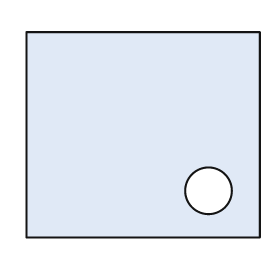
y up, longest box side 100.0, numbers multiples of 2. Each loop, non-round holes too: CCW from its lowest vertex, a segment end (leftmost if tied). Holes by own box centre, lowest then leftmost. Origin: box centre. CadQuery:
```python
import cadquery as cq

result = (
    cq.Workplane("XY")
    .moveTo(-50.0, -44.0)
    .lineTo(50.0, -44.0)
    .lineTo(50.0, 44.0)
    .lineTo(-50.0, 44.0)
    .close()
    .moveTo(28.0, -24.0)
    .circle(10.0)
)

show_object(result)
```